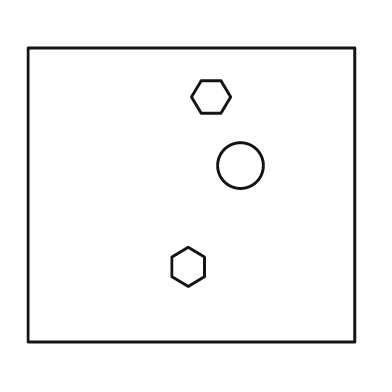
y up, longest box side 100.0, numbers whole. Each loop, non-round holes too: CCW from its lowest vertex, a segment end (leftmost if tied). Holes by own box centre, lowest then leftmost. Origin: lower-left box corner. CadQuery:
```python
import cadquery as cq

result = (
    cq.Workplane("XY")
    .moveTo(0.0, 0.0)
    .lineTo(100.0, 0.0)
    .lineTo(100.0, 90.0)
    .lineTo(0.0, 90.0)
    .close()
    .moveTo(49.0, 17.0)
    .lineTo(54.0, 20.0)
    .lineTo(54.0, 26.0)
    .lineTo(49.0, 29.0)
    .lineTo(44.0, 26.0)
    .lineTo(44.0, 20.0)
    .close()
    .moveTo(65.0, 54.0)
    .circle(7.0)
    .moveTo(53.0, 70.0)
    .lineTo(59.0, 70.0)
    .lineTo(62.0, 75.0)
    .lineTo(59.0, 80.0)
    .lineTo(53.0, 80.0)
    .lineTo(50.0, 75.0)
    .close()
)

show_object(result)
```